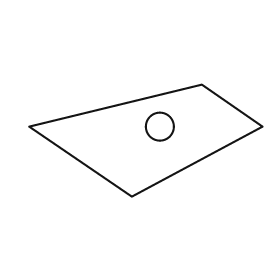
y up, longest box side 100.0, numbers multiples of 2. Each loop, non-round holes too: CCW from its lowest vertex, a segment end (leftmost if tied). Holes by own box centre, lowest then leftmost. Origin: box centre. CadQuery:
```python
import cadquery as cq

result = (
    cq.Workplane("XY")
    .moveTo(-6.0, -24.0)
    .lineTo(50.0, 6.0)
    .lineTo(24.0, 24.0)
    .lineTo(-50.0, 6.0)
    .close()
    .moveTo(6.0, 6.0)
    .circle(6.0)
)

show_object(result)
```